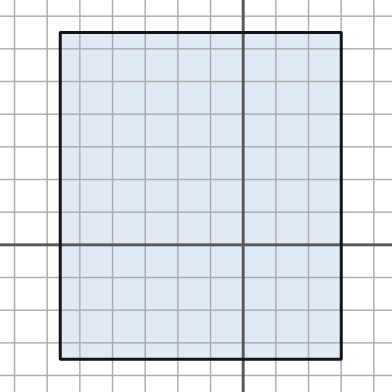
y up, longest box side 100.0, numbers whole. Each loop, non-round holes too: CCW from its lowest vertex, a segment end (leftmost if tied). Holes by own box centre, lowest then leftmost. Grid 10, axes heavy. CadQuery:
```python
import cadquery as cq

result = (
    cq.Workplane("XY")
    .moveTo(-56.0, -35.0)
    .lineTo(30.0, -35.0)
    .lineTo(30.0, 65.0)
    .lineTo(-56.0, 65.0)
    .close()
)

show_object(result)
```